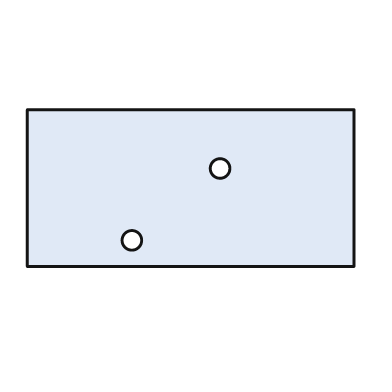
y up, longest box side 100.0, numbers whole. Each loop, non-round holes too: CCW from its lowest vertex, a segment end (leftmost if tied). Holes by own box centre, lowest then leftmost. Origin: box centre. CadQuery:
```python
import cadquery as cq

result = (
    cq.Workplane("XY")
    .moveTo(-50.0, -24.0)
    .lineTo(50.0, -24.0)
    .lineTo(50.0, 24.0)
    .lineTo(-50.0, 24.0)
    .close()
    .moveTo(-18.0, -16.0)
    .circle(3.0)
    .moveTo(9.0, 6.0)
    .circle(3.0)
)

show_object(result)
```